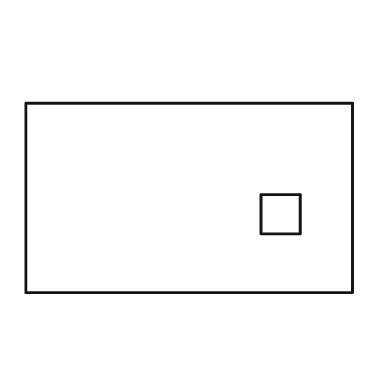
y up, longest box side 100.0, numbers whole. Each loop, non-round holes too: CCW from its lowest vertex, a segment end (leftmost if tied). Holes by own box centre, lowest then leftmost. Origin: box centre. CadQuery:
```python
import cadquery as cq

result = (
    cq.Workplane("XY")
    .moveTo(-50.0, -29.0)
    .lineTo(50.0, -29.0)
    .lineTo(50.0, 29.0)
    .lineTo(-50.0, 29.0)
    .close()
    .moveTo(22.0, -11.0)
    .lineTo(34.0, -11.0)
    .lineTo(34.0, 1.0)
    .lineTo(22.0, 1.0)
    .close()
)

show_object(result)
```